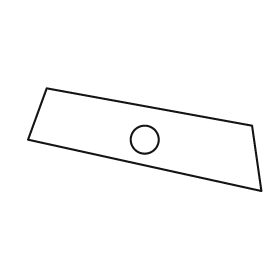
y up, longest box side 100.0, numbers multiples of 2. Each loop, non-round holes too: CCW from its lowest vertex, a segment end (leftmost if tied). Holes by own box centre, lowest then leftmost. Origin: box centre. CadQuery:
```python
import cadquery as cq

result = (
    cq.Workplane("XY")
    .moveTo(50.0, -22.0)
    .lineTo(46.0, 6.0)
    .lineTo(-42.0, 22.0)
    .lineTo(-50.0, 0.0)
    .close()
    .moveTo(0.0, 0.0)
    .circle(6.0)
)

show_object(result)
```